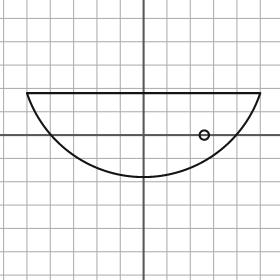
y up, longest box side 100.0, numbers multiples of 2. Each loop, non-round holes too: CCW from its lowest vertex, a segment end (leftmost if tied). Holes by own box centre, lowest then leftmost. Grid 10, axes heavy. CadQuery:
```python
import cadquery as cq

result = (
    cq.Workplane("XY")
    .moveTo(-50.0, 18.0)
    .threePointArc((0.0, -18.0), (50.0, 18.0))
    .close()
    .moveTo(26.0, 0.0)
    .circle(2.0)
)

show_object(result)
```